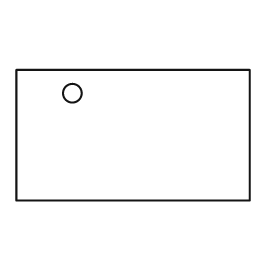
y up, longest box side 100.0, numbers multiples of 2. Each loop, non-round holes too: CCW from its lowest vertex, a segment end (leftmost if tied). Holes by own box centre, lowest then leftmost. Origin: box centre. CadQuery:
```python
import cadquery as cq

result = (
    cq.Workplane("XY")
    .moveTo(-50.0, -28.0)
    .lineTo(50.0, -28.0)
    .lineTo(50.0, 28.0)
    .lineTo(-50.0, 28.0)
    .close()
    .moveTo(-26.0, 18.0)
    .circle(4.0)
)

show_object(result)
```